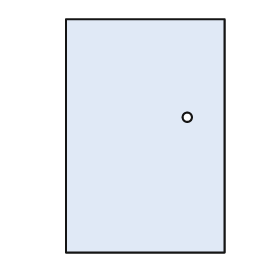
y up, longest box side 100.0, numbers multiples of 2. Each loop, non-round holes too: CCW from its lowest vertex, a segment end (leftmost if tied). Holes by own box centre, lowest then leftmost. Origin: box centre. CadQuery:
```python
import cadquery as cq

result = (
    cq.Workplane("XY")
    .moveTo(-34.0, -50.0)
    .lineTo(34.0, -50.0)
    .lineTo(34.0, 50.0)
    .lineTo(-34.0, 50.0)
    .close()
    .moveTo(18.0, 8.0)
    .circle(2.0)
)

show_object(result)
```